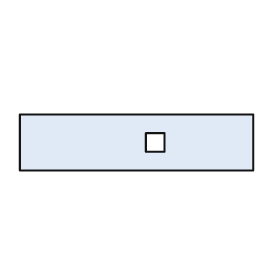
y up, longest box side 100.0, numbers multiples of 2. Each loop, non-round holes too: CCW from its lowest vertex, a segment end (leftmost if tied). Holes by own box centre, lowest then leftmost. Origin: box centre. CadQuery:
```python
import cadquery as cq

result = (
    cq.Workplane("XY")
    .moveTo(-50.0, -12.0)
    .lineTo(50.0, -12.0)
    .lineTo(50.0, 12.0)
    .lineTo(-50.0, 12.0)
    .close()
    .moveTo(4.0, -4.0)
    .lineTo(12.0, -4.0)
    .lineTo(12.0, 4.0)
    .lineTo(4.0, 4.0)
    .close()
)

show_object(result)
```